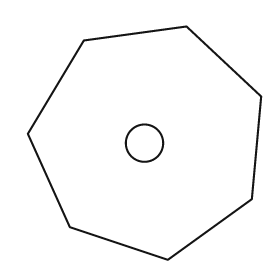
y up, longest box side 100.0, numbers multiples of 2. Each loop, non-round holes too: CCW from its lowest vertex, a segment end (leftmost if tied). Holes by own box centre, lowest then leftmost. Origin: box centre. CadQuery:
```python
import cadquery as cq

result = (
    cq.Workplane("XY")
    .moveTo(10.0, -50.0)
    .lineTo(46.0, -24.0)
    .lineTo(50.0, 20.0)
    .lineTo(18.0, 50.0)
    .lineTo(-26.0, 44.0)
    .lineTo(-50.0, 4.0)
    .lineTo(-32.0, -36.0)
    .close()
    .moveTo(0.0, 0.0)
    .circle(8.0)
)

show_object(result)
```